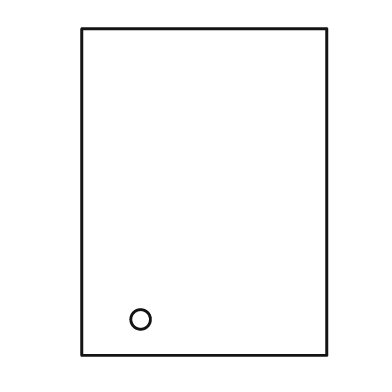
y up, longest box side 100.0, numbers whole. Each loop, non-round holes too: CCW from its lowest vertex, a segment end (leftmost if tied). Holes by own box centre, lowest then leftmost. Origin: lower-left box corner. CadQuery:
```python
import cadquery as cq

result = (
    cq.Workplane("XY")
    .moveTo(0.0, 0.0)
    .lineTo(75.0, 0.0)
    .lineTo(75.0, 100.0)
    .lineTo(0.0, 100.0)
    .close()
    .moveTo(18.0, 11.0)
    .circle(3.0)
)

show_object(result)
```